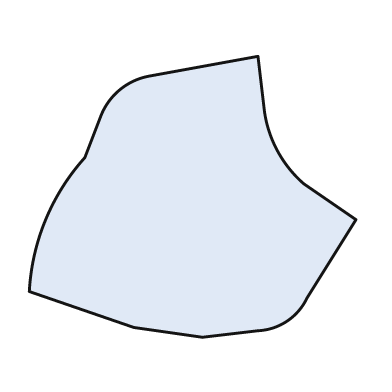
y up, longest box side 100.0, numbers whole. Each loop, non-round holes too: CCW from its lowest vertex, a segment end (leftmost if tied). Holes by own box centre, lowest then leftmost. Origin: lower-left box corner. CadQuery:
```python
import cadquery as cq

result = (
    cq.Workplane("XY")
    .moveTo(53.0, 0.0)
    .lineTo(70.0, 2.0)
    .threePointArc((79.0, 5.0), (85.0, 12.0))
    .lineTo(100.0, 36.0)
    .lineTo(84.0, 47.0)
    .threePointArc((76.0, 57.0), (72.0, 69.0))
    .lineTo(70.0, 86.0)
    .lineTo(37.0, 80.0)
    .threePointArc((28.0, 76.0), (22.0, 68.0))
    .lineTo(17.0, 55.0)
    .threePointArc((5.0, 36.0), (0.0, 14.0))
    .lineTo(32.0, 3.0)
    .close()
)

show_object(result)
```